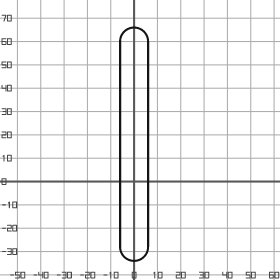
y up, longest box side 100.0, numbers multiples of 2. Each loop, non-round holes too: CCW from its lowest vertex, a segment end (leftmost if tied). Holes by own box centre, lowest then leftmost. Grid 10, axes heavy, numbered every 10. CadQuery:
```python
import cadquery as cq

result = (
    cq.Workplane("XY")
    .moveTo(-6.0, -28.0)
    .threePointArc((0.0, -34.0), (6.0, -28.0))
    .lineTo(6.0, 60.0)
    .threePointArc((0.0, 66.0), (-6.0, 60.0))
    .close()
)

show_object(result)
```